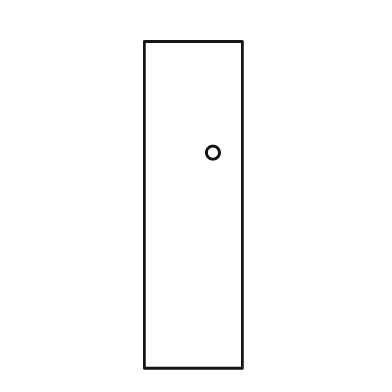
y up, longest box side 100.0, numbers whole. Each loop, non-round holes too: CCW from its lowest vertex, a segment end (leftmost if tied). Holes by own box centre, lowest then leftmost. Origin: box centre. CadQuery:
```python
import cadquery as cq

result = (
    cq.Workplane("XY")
    .moveTo(-15.0, -50.0)
    .lineTo(15.0, -50.0)
    .lineTo(15.0, 50.0)
    .lineTo(-15.0, 50.0)
    .close()
    .moveTo(6.0, 16.0)
    .circle(2.0)
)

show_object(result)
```